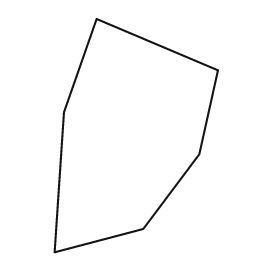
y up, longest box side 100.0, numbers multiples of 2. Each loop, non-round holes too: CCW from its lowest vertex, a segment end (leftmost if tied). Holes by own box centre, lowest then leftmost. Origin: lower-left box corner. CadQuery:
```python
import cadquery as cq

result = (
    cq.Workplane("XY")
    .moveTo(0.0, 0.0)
    .lineTo(38.0, 10.0)
    .lineTo(62.0, 42.0)
    .lineTo(70.0, 78.0)
    .lineTo(18.0, 100.0)
    .lineTo(4.0, 60.0)
    .close()
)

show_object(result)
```